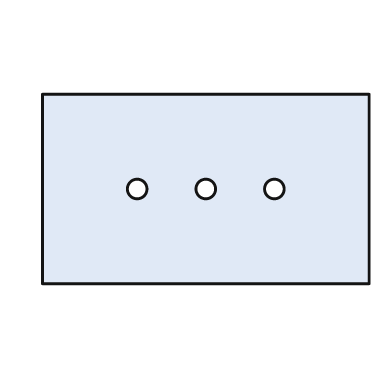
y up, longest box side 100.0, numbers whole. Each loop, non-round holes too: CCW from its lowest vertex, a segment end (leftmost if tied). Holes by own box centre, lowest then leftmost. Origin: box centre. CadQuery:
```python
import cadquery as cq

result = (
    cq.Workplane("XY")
    .moveTo(-50.0, -29.0)
    .lineTo(50.0, -29.0)
    .lineTo(50.0, 29.0)
    .lineTo(-50.0, 29.0)
    .close()
    .moveTo(-21.0, 0.0)
    .circle(3.0)
    .moveTo(0.0, 0.0)
    .circle(3.0)
    .moveTo(21.0, 0.0)
    .circle(3.0)
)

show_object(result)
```